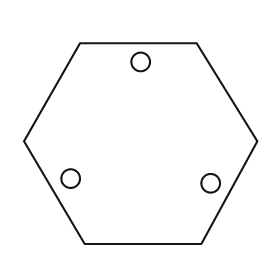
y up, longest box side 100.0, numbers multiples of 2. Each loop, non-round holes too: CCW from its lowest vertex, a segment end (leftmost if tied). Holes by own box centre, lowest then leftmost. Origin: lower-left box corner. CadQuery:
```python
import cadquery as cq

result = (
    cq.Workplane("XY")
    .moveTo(26.0, 0.0)
    .lineTo(76.0, 0.0)
    .lineTo(100.0, 44.0)
    .lineTo(74.0, 86.0)
    .lineTo(24.0, 86.0)
    .lineTo(0.0, 44.0)
    .close()
    .moveTo(80.0, 26.0)
    .circle(4.0)
    .moveTo(20.0, 28.0)
    .circle(4.0)
    .moveTo(50.0, 78.0)
    .circle(4.0)
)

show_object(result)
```